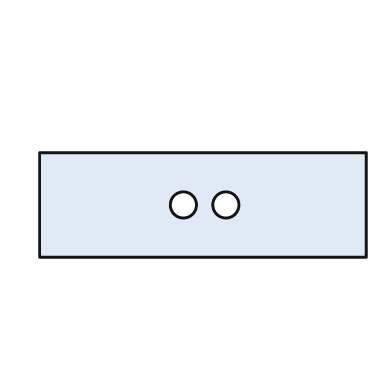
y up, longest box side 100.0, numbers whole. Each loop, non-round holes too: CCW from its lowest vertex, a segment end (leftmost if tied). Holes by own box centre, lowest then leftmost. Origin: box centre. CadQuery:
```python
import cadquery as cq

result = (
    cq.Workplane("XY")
    .moveTo(-50.0, -16.0)
    .lineTo(50.0, -16.0)
    .lineTo(50.0, 16.0)
    .lineTo(-50.0, 16.0)
    .close()
    .moveTo(-6.0, 0.0)
    .circle(4.0)
    .moveTo(7.0, 0.0)
    .circle(4.0)
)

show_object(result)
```